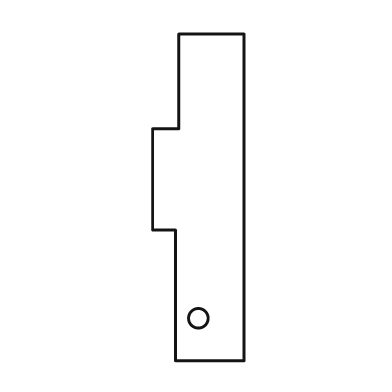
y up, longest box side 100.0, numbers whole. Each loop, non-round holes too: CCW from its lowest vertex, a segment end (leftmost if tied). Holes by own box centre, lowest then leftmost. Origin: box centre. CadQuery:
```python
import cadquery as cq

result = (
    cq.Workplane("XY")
    .moveTo(-7.0, -50.0)
    .lineTo(14.0, -50.0)
    .lineTo(14.0, 50.0)
    .lineTo(-6.0, 50.0)
    .lineTo(-6.0, 21.0)
    .lineTo(-14.0, 21.0)
    .lineTo(-14.0, -10.0)
    .lineTo(-7.0, -10.0)
    .close()
    .moveTo(0.0, -37.0)
    .circle(3.0)
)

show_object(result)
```